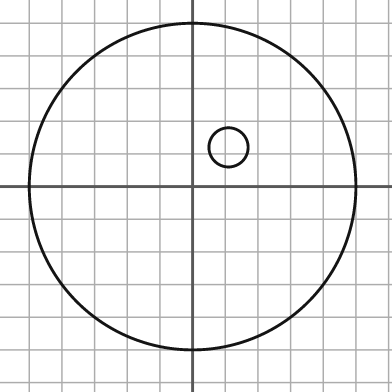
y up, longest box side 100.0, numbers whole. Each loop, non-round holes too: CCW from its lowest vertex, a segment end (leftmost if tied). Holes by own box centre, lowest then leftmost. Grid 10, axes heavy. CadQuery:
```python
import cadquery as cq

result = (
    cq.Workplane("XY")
    .moveTo(0.0, 0.0)
    .circle(50.0)
    .moveTo(11.0, 12.0)
    .circle(6.0)
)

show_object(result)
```